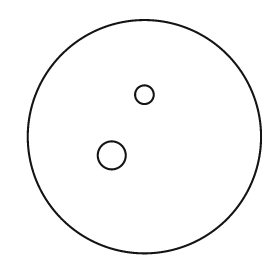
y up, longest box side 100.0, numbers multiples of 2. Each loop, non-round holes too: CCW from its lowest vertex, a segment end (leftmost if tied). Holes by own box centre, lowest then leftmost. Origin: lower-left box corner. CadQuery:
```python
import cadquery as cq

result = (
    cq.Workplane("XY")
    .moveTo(50.0, 50.0)
    .circle(50.0)
    .moveTo(36.0, 42.0)
    .circle(6.0)
    .moveTo(50.0, 68.0)
    .circle(4.0)
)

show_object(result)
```